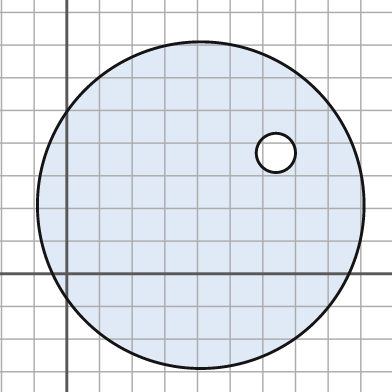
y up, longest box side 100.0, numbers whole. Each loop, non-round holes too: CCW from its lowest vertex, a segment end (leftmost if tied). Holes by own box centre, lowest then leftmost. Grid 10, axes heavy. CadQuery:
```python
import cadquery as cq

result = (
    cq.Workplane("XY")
    .moveTo(41.0, 21.0)
    .circle(50.0)
    .moveTo(64.0, 37.0)
    .circle(6.0)
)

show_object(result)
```